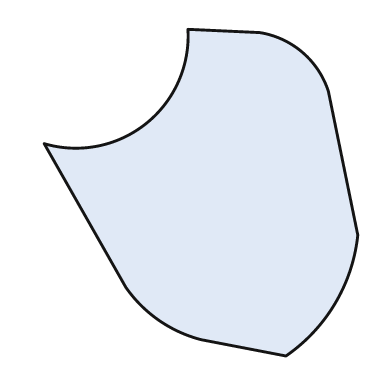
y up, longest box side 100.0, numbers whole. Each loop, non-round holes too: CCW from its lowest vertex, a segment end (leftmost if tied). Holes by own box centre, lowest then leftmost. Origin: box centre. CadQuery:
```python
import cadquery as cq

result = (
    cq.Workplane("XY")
    .moveTo(26.0, -50.0)
    .threePointArc((41.0, -34.0), (48.0, -13.0))
    .lineTo(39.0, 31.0)
    .threePointArc((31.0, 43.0), (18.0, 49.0))
    .lineTo(-4.0, 50.0)
    .threePointArc((-17.0, 21.0), (-48.0, 15.0))
    .lineTo(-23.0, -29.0)
    .threePointArc((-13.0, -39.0), (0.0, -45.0))
    .close()
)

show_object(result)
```